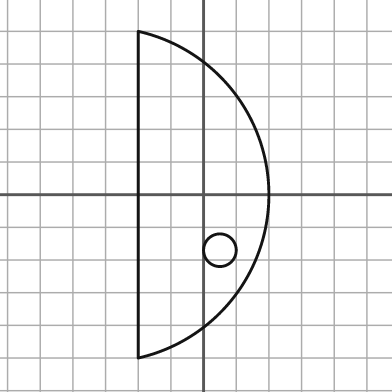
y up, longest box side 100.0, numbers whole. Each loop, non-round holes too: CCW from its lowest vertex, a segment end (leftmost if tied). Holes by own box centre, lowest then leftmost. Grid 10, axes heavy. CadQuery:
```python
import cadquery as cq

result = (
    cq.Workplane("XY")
    .moveTo(-20.0, -50.0)
    .threePointArc((20.0, 0.0), (-20.0, 50.0))
    .close()
    .moveTo(5.0, -17.0)
    .circle(5.0)
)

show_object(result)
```